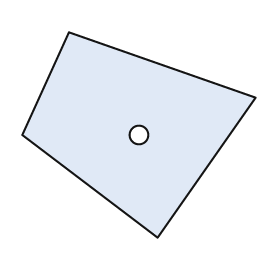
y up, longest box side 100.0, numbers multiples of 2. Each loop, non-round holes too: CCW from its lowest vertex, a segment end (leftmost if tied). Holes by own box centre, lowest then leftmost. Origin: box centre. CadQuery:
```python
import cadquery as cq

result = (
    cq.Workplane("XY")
    .moveTo(8.0, -44.0)
    .lineTo(50.0, 16.0)
    .lineTo(-30.0, 44.0)
    .lineTo(-50.0, 0.0)
    .close()
    .moveTo(0.0, 0.0)
    .circle(4.0)
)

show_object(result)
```